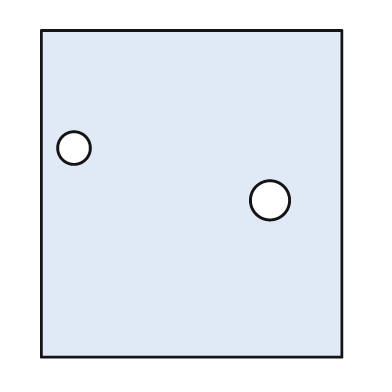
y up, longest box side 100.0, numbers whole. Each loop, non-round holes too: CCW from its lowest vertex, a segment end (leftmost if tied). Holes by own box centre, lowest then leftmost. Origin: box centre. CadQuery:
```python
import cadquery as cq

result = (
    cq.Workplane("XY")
    .moveTo(-46.0, -50.0)
    .lineTo(46.0, -50.0)
    .lineTo(46.0, 50.0)
    .lineTo(-46.0, 50.0)
    .close()
    .moveTo(24.0, -2.0)
    .circle(6.0)
    .moveTo(-36.0, 14.0)
    .circle(5.0)
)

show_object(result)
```